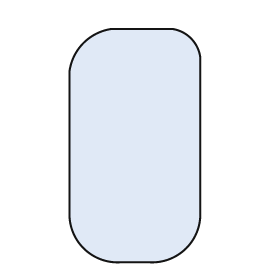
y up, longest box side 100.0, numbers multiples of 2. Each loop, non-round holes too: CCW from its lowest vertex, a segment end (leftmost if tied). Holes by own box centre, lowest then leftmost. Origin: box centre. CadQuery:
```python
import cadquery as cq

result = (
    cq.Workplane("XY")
    .moveTo(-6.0, -50.0)
    .lineTo(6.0, -50.0)
    .threePointArc((22.0, -44.0), (28.0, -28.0))
    .lineTo(28.0, 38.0)
    .threePointArc((24.0, 46.0), (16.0, 50.0))
    .lineTo(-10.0, 50.0)
    .threePointArc((-22.0, 44.0), (-28.0, 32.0))
    .lineTo(-28.0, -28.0)
    .threePointArc((-22.0, -44.0), (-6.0, -50.0))
    .close()
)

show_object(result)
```